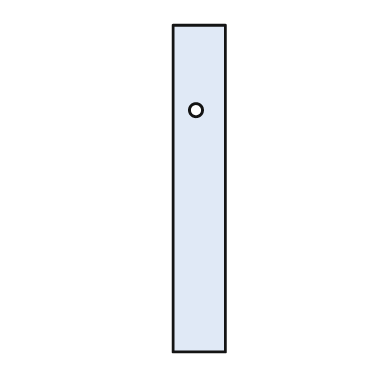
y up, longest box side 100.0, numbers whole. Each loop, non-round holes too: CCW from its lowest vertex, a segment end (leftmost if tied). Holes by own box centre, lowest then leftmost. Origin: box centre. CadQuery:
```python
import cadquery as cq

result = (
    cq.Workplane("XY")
    .moveTo(-8.0, -50.0)
    .lineTo(8.0, -50.0)
    .lineTo(8.0, 50.0)
    .lineTo(-8.0, 50.0)
    .close()
    .moveTo(-1.0, 24.0)
    .circle(2.0)
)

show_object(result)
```